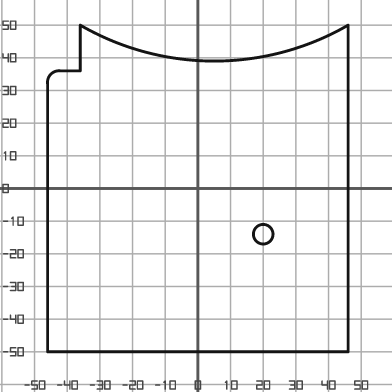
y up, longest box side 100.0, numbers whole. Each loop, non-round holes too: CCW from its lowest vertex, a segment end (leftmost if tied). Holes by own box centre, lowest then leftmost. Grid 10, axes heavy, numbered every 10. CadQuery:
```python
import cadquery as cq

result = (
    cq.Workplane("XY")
    .moveTo(-46.0, -50.0)
    .lineTo(46.0, -50.0)
    .lineTo(46.0, 50.0)
    .threePointArc((5.0, 39.0), (-36.0, 50.0))
    .lineTo(-36.0, 36.0)
    .lineTo(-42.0, 36.0)
    .threePointArc((-45.0, 35.0), (-46.0, 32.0))
    .close()
    .moveTo(20.0, -14.0)
    .circle(3.0)
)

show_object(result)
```